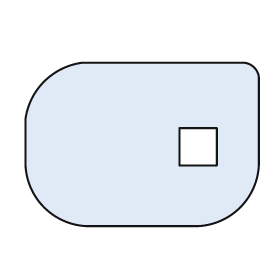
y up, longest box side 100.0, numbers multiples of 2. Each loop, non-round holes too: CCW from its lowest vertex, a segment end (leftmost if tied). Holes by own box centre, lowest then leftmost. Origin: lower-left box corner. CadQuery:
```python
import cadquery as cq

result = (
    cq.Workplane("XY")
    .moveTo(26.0, 0.0)
    .lineTo(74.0, 0.0)
    .threePointArc((92.0, 8.0), (100.0, 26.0))
    .lineTo(100.0, 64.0)
    .threePointArc((98.0, 68.0), (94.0, 70.0))
    .lineTo(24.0, 70.0)
    .threePointArc((8.0, 62.0), (0.0, 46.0))
    .lineTo(0.0, 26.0)
    .threePointArc((8.0, 8.0), (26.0, 0.0))
    .close()
    .moveTo(66.0, 26.0)
    .lineTo(82.0, 26.0)
    .lineTo(82.0, 42.0)
    .lineTo(66.0, 42.0)
    .close()
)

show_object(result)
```